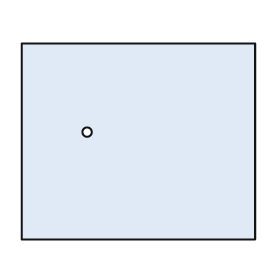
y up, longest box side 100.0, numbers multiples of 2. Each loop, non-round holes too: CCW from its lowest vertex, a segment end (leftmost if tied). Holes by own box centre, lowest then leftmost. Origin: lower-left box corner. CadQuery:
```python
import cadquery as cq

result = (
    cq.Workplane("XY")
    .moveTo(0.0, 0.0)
    .lineTo(100.0, 0.0)
    .lineTo(100.0, 84.0)
    .lineTo(0.0, 84.0)
    .close()
    .moveTo(28.0, 46.0)
    .circle(2.0)
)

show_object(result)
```